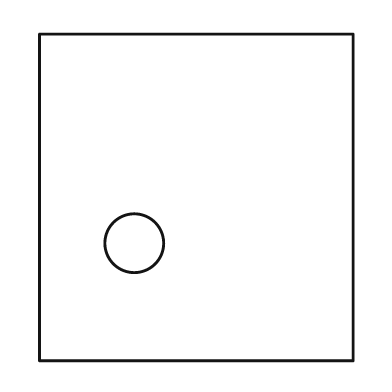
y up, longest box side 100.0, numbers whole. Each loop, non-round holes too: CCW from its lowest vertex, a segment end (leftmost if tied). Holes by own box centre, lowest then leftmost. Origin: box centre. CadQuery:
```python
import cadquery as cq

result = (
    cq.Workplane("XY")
    .moveTo(-48.0, -50.0)
    .lineTo(48.0, -50.0)
    .lineTo(48.0, 50.0)
    .lineTo(-48.0, 50.0)
    .close()
    .moveTo(-19.0, -14.0)
    .circle(9.0)
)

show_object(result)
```